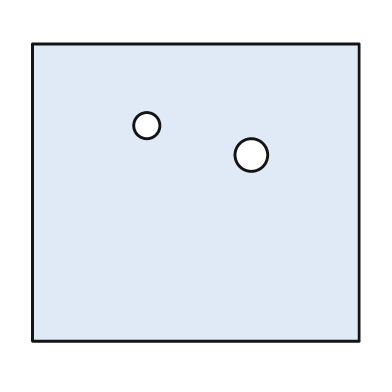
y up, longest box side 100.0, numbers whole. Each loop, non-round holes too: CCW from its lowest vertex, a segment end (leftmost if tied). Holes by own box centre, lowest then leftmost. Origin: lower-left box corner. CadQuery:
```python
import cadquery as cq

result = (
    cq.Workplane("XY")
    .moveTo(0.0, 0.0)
    .lineTo(100.0, 0.0)
    .lineTo(100.0, 91.0)
    .lineTo(0.0, 91.0)
    .close()
    .moveTo(67.0, 57.0)
    .circle(5.0)
    .moveTo(35.0, 66.0)
    .circle(4.0)
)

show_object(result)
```